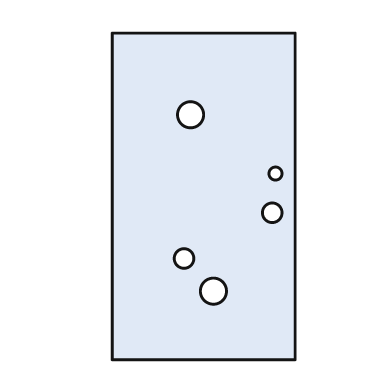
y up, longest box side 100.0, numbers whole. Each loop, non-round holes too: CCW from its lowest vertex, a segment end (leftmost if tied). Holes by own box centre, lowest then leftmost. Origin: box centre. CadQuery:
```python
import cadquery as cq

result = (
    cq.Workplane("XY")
    .moveTo(-28.0, -50.0)
    .lineTo(28.0, -50.0)
    .lineTo(28.0, 50.0)
    .lineTo(-28.0, 50.0)
    .close()
    .moveTo(3.0, -29.0)
    .circle(4.0)
    .moveTo(-6.0, -19.0)
    .circle(3.0)
    .moveTo(21.0, -5.0)
    .circle(3.0)
    .moveTo(22.0, 7.0)
    .circle(2.0)
    .moveTo(-4.0, 25.0)
    .circle(4.0)
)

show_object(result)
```